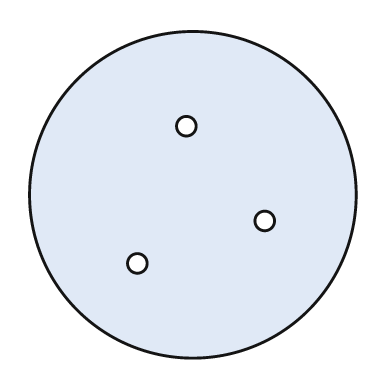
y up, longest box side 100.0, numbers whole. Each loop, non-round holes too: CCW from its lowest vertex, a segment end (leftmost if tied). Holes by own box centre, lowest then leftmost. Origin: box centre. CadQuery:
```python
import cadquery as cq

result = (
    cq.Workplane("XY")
    .moveTo(0.0, 0.0)
    .circle(50.0)
    .moveTo(-17.0, -21.0)
    .circle(3.0)
    .moveTo(22.0, -8.0)
    .circle(3.0)
    .moveTo(-2.0, 21.0)
    .circle(3.0)
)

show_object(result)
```